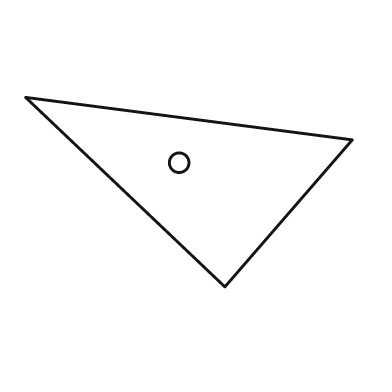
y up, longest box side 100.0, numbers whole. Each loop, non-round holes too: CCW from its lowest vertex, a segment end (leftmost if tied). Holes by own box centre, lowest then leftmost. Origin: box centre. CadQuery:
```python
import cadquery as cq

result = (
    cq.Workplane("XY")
    .moveTo(11.0, -29.0)
    .lineTo(50.0, 16.0)
    .lineTo(-50.0, 29.0)
    .close()
    .moveTo(-3.0, 9.0)
    .circle(3.0)
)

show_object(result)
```